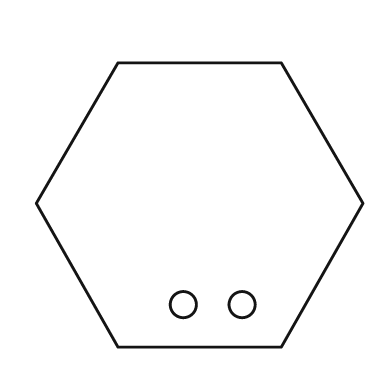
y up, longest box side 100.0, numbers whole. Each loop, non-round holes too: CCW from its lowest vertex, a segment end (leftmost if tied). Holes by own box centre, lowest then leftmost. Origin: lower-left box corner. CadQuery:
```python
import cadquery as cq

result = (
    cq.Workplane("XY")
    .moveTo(25.0, 0.0)
    .lineTo(75.0, 0.0)
    .lineTo(100.0, 44.0)
    .lineTo(75.0, 87.0)
    .lineTo(25.0, 87.0)
    .lineTo(0.0, 44.0)
    .close()
    .moveTo(45.0, 13.0)
    .circle(4.0)
    .moveTo(63.0, 13.0)
    .circle(4.0)
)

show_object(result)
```